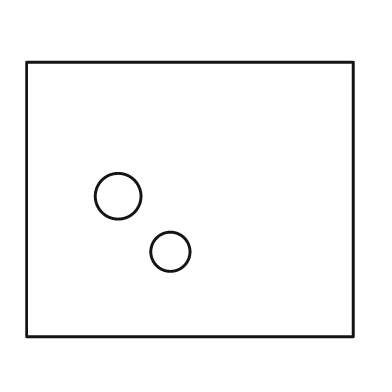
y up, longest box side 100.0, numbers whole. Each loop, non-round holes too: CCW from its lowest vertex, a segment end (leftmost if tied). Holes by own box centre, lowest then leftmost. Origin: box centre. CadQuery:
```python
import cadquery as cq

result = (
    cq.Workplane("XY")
    .moveTo(-50.0, -42.0)
    .lineTo(50.0, -42.0)
    .lineTo(50.0, 42.0)
    .lineTo(-50.0, 42.0)
    .close()
    .moveTo(-6.0, -16.0)
    .circle(6.0)
    .moveTo(-22.0, 1.0)
    .circle(7.0)
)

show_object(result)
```